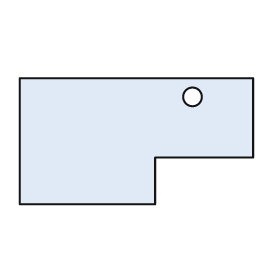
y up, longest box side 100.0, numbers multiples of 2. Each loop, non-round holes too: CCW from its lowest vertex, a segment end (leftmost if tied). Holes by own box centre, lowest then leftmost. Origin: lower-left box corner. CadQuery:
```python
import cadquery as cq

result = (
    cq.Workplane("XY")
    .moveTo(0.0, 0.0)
    .lineTo(58.0, 0.0)
    .lineTo(58.0, 20.0)
    .lineTo(100.0, 20.0)
    .lineTo(100.0, 54.0)
    .lineTo(0.0, 54.0)
    .close()
    .moveTo(74.0, 46.0)
    .circle(4.0)
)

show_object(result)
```